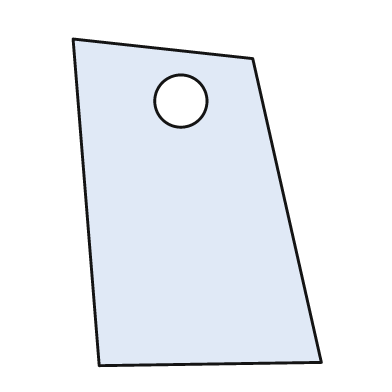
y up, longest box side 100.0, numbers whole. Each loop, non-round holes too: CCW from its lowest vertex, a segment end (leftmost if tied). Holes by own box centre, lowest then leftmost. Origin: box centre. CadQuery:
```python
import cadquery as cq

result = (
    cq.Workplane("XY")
    .moveTo(-30.0, -50.0)
    .lineTo(38.0, -49.0)
    .lineTo(17.0, 44.0)
    .lineTo(-38.0, 50.0)
    .close()
    .moveTo(-5.0, 31.0)
    .circle(8.0)
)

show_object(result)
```